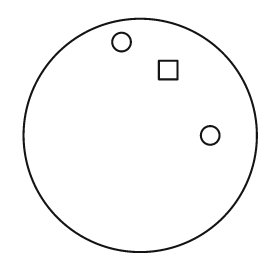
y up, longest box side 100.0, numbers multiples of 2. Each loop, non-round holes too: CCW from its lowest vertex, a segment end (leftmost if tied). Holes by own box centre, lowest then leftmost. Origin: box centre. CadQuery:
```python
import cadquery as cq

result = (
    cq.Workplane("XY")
    .moveTo(0.0, 0.0)
    .circle(50.0)
    .moveTo(30.0, 0.0)
    .circle(4.0)
    .moveTo(8.0, 24.0)
    .lineTo(16.0, 24.0)
    .lineTo(16.0, 32.0)
    .lineTo(8.0, 32.0)
    .close()
    .moveTo(-8.0, 40.0)
    .circle(4.0)
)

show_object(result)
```